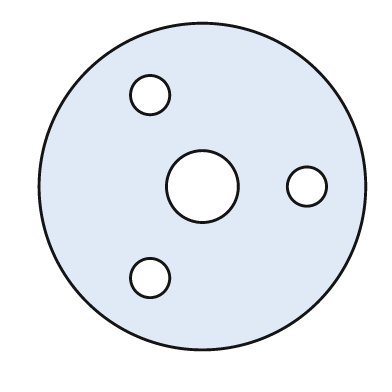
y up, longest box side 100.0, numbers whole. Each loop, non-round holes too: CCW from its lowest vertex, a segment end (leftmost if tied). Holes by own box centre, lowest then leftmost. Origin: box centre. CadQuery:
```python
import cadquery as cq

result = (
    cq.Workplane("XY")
    .moveTo(0.0, 0.0)
    .circle(50.0)
    .moveTo(-16.0, -28.0)
    .circle(6.0)
    .moveTo(0.0, 0.0)
    .circle(11.0)
    .moveTo(32.0, 0.0)
    .circle(6.0)
    .moveTo(-16.0, 28.0)
    .circle(6.0)
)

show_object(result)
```